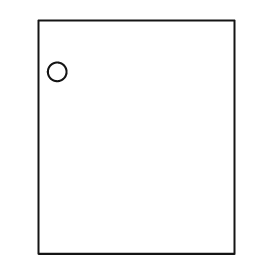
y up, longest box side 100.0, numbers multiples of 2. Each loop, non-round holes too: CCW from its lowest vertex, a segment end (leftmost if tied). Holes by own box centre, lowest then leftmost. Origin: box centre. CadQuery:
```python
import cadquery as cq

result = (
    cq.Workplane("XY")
    .moveTo(-42.0, -50.0)
    .lineTo(42.0, -50.0)
    .lineTo(42.0, 50.0)
    .lineTo(-42.0, 50.0)
    .close()
    .moveTo(-34.0, 28.0)
    .circle(4.0)
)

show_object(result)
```